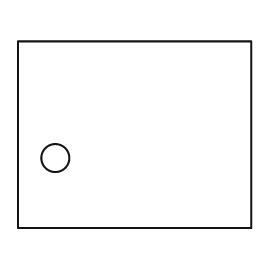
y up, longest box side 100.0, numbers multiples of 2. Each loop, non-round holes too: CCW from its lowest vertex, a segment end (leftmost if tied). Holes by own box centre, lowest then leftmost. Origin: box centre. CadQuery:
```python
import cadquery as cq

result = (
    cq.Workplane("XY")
    .moveTo(-50.0, -40.0)
    .lineTo(50.0, -40.0)
    .lineTo(50.0, 40.0)
    .lineTo(-50.0, 40.0)
    .close()
    .moveTo(-34.0, -10.0)
    .circle(6.0)
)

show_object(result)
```